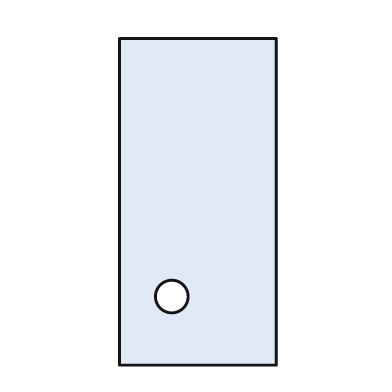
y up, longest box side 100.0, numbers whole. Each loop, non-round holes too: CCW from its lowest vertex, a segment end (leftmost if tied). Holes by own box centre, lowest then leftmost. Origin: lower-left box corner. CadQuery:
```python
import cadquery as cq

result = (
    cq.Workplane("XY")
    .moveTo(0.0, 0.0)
    .lineTo(48.0, 0.0)
    .lineTo(48.0, 100.0)
    .lineTo(0.0, 100.0)
    .close()
    .moveTo(16.0, 21.0)
    .circle(5.0)
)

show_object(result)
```